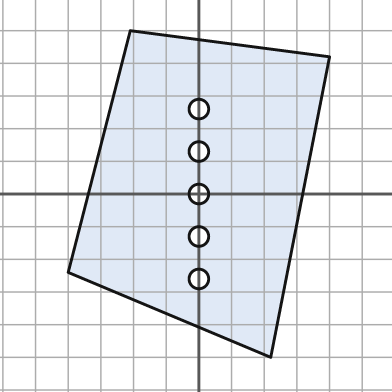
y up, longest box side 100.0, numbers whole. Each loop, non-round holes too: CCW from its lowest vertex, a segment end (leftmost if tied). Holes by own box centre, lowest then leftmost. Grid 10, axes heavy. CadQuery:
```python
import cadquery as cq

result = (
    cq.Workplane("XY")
    .moveTo(22.0, -50.0)
    .lineTo(40.0, 42.0)
    .lineTo(-21.0, 50.0)
    .lineTo(-40.0, -24.0)
    .close()
    .moveTo(0.0, -26.0)
    .circle(3.0)
    .moveTo(0.0, -13.0)
    .circle(3.0)
    .moveTo(0.0, 0.0)
    .circle(3.0)
    .moveTo(0.0, 13.0)
    .circle(3.0)
    .moveTo(0.0, 26.0)
    .circle(3.0)
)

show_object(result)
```